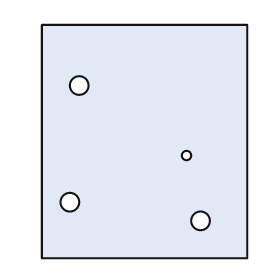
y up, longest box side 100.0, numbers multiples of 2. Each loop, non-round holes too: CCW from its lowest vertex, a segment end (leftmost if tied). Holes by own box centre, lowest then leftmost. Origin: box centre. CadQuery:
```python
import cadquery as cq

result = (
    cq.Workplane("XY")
    .moveTo(-44.0, -50.0)
    .lineTo(44.0, -50.0)
    .lineTo(44.0, 50.0)
    .lineTo(-44.0, 50.0)
    .close()
    .moveTo(24.0, -34.0)
    .circle(4.0)
    .moveTo(-32.0, -26.0)
    .circle(4.0)
    .moveTo(18.0, -6.0)
    .circle(2.0)
    .moveTo(-28.0, 24.0)
    .circle(4.0)
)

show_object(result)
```